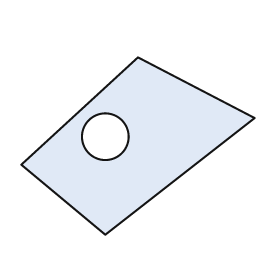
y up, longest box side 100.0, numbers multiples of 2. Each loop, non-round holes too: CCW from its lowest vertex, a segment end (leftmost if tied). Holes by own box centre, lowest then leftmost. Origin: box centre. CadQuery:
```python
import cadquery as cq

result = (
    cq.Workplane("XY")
    .moveTo(-14.0, -38.0)
    .lineTo(50.0, 12.0)
    .lineTo(0.0, 38.0)
    .lineTo(-50.0, -8.0)
    .close()
    .moveTo(-14.0, 4.0)
    .circle(10.0)
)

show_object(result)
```